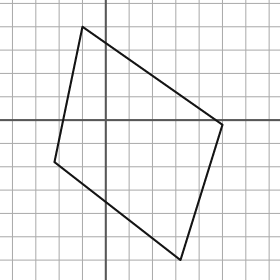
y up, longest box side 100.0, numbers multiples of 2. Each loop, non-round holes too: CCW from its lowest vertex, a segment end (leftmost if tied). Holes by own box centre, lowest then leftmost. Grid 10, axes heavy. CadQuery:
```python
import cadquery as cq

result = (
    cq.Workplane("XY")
    .moveTo(32.0, -60.0)
    .lineTo(50.0, -2.0)
    .lineTo(-10.0, 40.0)
    .lineTo(-22.0, -18.0)
    .close()
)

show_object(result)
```